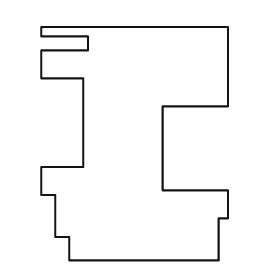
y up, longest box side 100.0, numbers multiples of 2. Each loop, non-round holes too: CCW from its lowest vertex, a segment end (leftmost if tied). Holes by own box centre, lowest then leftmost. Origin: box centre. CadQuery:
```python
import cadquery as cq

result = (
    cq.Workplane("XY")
    .moveTo(-28.0, -50.0)
    .lineTo(36.0, -50.0)
    .lineTo(36.0, -32.0)
    .lineTo(40.0, -32.0)
    .lineTo(40.0, -20.0)
    .lineTo(12.0, -20.0)
    .lineTo(12.0, 16.0)
    .lineTo(40.0, 16.0)
    .lineTo(40.0, 50.0)
    .lineTo(-40.0, 50.0)
    .lineTo(-40.0, 46.0)
    .lineTo(-20.0, 46.0)
    .lineTo(-20.0, 40.0)
    .lineTo(-40.0, 40.0)
    .lineTo(-40.0, 28.0)
    .lineTo(-22.0, 28.0)
    .lineTo(-22.0, -10.0)
    .lineTo(-40.0, -10.0)
    .lineTo(-40.0, -22.0)
    .lineTo(-34.0, -22.0)
    .lineTo(-34.0, -40.0)
    .lineTo(-28.0, -40.0)
    .close()
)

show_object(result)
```